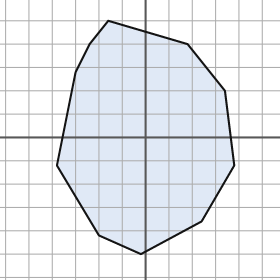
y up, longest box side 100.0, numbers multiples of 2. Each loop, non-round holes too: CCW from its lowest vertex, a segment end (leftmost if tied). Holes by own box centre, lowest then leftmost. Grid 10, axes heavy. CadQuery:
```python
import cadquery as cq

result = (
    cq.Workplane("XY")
    .moveTo(-2.0, -50.0)
    .lineTo(24.0, -36.0)
    .lineTo(38.0, -12.0)
    .lineTo(34.0, 20.0)
    .lineTo(18.0, 40.0)
    .lineTo(-16.0, 50.0)
    .lineTo(-24.0, 40.0)
    .lineTo(-30.0, 28.0)
    .lineTo(-38.0, -12.0)
    .lineTo(-20.0, -42.0)
    .close()
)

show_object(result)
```